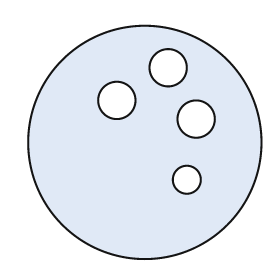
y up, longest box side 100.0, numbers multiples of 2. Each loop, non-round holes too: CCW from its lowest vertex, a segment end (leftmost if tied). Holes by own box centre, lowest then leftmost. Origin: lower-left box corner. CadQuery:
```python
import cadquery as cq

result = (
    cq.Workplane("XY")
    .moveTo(50.0, 50.0)
    .circle(50.0)
    .moveTo(68.0, 34.0)
    .circle(6.0)
    .moveTo(72.0, 60.0)
    .circle(8.0)
    .moveTo(38.0, 68.0)
    .circle(8.0)
    .moveTo(60.0, 82.0)
    .circle(8.0)
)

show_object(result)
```